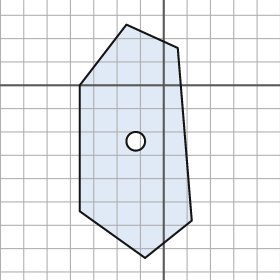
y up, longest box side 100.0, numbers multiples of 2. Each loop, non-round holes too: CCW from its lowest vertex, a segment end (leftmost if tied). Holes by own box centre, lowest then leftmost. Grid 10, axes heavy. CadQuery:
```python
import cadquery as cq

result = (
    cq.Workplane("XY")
    .moveTo(-8.0, -74.0)
    .lineTo(12.0, -58.0)
    .lineTo(6.0, 16.0)
    .lineTo(-16.0, 26.0)
    .lineTo(-36.0, 0.0)
    .lineTo(-36.0, -54.0)
    .close()
    .moveTo(-12.0, -24.0)
    .circle(4.0)
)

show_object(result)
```